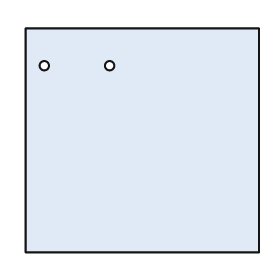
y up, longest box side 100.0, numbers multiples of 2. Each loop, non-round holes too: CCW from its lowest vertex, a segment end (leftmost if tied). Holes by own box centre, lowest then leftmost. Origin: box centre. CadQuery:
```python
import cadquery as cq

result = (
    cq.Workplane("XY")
    .moveTo(-50.0, -48.0)
    .lineTo(50.0, -48.0)
    .lineTo(50.0, 48.0)
    .lineTo(-50.0, 48.0)
    .close()
    .moveTo(-42.0, 32.0)
    .circle(2.0)
    .moveTo(-14.0, 32.0)
    .circle(2.0)
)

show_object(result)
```